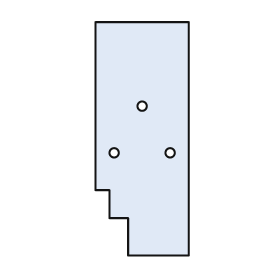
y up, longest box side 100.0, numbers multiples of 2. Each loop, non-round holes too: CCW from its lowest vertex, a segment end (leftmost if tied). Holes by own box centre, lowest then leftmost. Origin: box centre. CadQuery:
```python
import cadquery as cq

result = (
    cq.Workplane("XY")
    .moveTo(-6.0, -50.0)
    .lineTo(20.0, -50.0)
    .lineTo(20.0, 50.0)
    .lineTo(-20.0, 50.0)
    .lineTo(-20.0, -22.0)
    .lineTo(-14.0, -22.0)
    .lineTo(-14.0, -34.0)
    .lineTo(-6.0, -34.0)
    .close()
    .moveTo(-12.0, -6.0)
    .circle(2.0)
    .moveTo(12.0, -6.0)
    .circle(2.0)
    .moveTo(0.0, 14.0)
    .circle(2.0)
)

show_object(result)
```